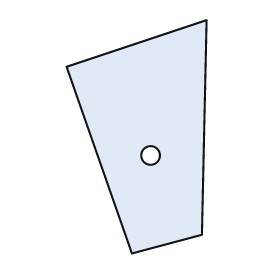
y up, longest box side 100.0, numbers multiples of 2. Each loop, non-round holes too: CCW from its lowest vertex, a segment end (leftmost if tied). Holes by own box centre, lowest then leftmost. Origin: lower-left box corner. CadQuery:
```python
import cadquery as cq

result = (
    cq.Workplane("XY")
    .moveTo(28.0, 0.0)
    .lineTo(58.0, 8.0)
    .lineTo(60.0, 100.0)
    .lineTo(0.0, 80.0)
    .close()
    .moveTo(36.0, 42.0)
    .circle(4.0)
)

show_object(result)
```